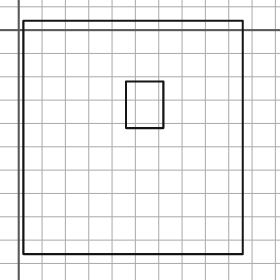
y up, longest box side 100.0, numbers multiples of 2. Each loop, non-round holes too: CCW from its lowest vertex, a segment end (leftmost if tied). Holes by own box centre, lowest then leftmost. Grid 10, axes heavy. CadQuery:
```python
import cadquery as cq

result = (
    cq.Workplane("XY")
    .moveTo(2.0, -96.0)
    .lineTo(96.0, -96.0)
    .lineTo(96.0, 4.0)
    .lineTo(2.0, 4.0)
    .close()
    .moveTo(46.0, -42.0)
    .lineTo(62.0, -42.0)
    .lineTo(62.0, -22.0)
    .lineTo(46.0, -22.0)
    .close()
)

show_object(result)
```